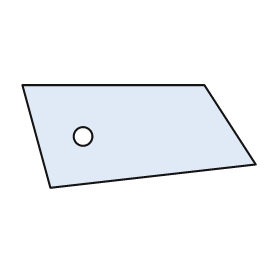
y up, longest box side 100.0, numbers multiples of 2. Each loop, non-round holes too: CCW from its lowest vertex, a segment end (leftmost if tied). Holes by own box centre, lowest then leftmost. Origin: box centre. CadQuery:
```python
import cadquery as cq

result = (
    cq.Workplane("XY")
    .moveTo(-38.0, -22.0)
    .lineTo(50.0, -12.0)
    .lineTo(28.0, 22.0)
    .lineTo(-50.0, 22.0)
    .close()
    .moveTo(-24.0, 0.0)
    .circle(4.0)
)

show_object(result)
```